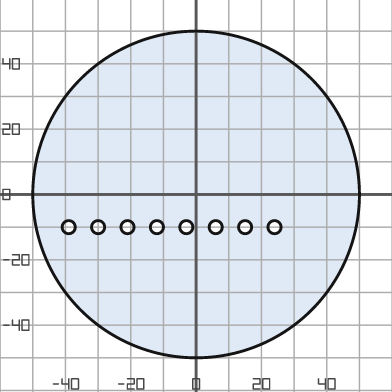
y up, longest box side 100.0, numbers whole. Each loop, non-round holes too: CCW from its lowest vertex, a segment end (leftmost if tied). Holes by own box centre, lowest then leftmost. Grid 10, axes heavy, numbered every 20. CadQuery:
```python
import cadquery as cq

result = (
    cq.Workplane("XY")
    .moveTo(0.0, 0.0)
    .circle(50.0)
    .moveTo(-39.0, -10.0)
    .circle(2.0)
    .moveTo(-30.0, -10.0)
    .circle(2.0)
    .moveTo(-21.0, -10.0)
    .circle(2.0)
    .moveTo(-12.0, -10.0)
    .circle(2.0)
    .moveTo(-3.0, -10.0)
    .circle(2.0)
    .moveTo(6.0, -10.0)
    .circle(2.0)
    .moveTo(15.0, -10.0)
    .circle(2.0)
    .moveTo(24.0, -10.0)
    .circle(2.0)
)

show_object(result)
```